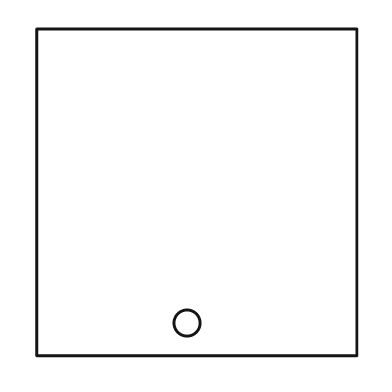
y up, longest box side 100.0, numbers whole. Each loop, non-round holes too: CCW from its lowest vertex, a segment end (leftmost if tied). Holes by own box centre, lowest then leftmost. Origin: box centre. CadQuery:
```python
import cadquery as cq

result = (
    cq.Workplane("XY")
    .moveTo(-49.0, -50.0)
    .lineTo(49.0, -50.0)
    .lineTo(49.0, 50.0)
    .lineTo(-49.0, 50.0)
    .close()
    .moveTo(-3.0, -40.0)
    .circle(4.0)
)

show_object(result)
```